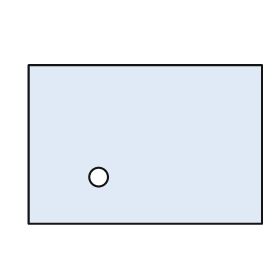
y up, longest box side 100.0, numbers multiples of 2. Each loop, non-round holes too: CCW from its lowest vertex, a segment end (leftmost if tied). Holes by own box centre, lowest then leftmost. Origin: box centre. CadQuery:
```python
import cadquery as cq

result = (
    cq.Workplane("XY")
    .moveTo(-50.0, -34.0)
    .lineTo(50.0, -34.0)
    .lineTo(50.0, 34.0)
    .lineTo(-50.0, 34.0)
    .close()
    .moveTo(-20.0, -14.0)
    .circle(4.0)
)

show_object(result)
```